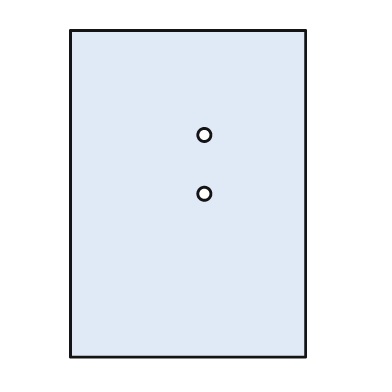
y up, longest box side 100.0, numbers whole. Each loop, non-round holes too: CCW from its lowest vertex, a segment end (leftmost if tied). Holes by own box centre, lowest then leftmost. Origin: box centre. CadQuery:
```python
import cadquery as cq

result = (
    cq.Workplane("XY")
    .moveTo(-36.0, -50.0)
    .lineTo(36.0, -50.0)
    .lineTo(36.0, 50.0)
    .lineTo(-36.0, 50.0)
    .close()
    .moveTo(5.0, 0.0)
    .circle(2.0)
    .moveTo(5.0, 18.0)
    .circle(2.0)
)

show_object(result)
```